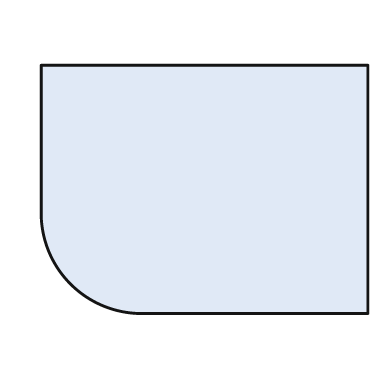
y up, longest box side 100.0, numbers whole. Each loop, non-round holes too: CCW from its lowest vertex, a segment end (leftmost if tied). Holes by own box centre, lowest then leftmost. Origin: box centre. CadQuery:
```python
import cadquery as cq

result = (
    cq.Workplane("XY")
    .moveTo(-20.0, -38.0)
    .lineTo(50.0, -38.0)
    .lineTo(50.0, 38.0)
    .lineTo(-50.0, 38.0)
    .lineTo(-50.0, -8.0)
    .threePointArc((-41.0, -29.0), (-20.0, -38.0))
    .close()
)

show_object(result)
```